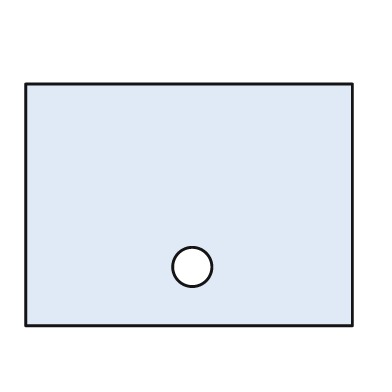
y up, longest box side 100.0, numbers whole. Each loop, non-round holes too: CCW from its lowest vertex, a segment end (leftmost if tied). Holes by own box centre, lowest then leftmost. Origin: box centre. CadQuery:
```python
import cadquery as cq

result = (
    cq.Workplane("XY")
    .moveTo(-50.0, -37.0)
    .lineTo(50.0, -37.0)
    .lineTo(50.0, 37.0)
    .lineTo(-50.0, 37.0)
    .close()
    .moveTo(1.0, -19.0)
    .circle(6.0)
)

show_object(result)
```